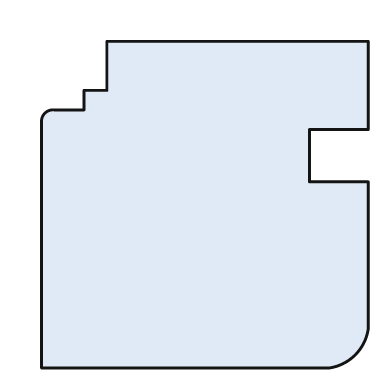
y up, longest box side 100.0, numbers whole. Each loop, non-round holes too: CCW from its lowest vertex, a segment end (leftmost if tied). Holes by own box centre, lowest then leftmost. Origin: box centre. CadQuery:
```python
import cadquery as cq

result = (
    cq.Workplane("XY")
    .moveTo(-50.0, -50.0)
    .lineTo(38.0, -50.0)
    .threePointArc((46.0, -46.0), (50.0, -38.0))
    .lineTo(50.0, 7.0)
    .lineTo(32.0, 7.0)
    .lineTo(32.0, 23.0)
    .lineTo(50.0, 23.0)
    .lineTo(50.0, 50.0)
    .lineTo(-30.0, 50.0)
    .lineTo(-30.0, 35.0)
    .lineTo(-37.0, 35.0)
    .lineTo(-37.0, 29.0)
    .lineTo(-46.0, 29.0)
    .threePointArc((-49.0, 28.0), (-50.0, 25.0))
    .close()
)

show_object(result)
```